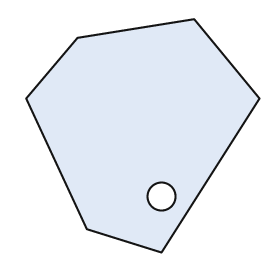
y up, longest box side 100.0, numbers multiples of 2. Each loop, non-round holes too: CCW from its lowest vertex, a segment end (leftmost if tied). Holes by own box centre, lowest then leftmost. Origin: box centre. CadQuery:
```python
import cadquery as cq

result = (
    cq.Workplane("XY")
    .moveTo(8.0, -50.0)
    .lineTo(50.0, 16.0)
    .lineTo(22.0, 50.0)
    .lineTo(-28.0, 42.0)
    .lineTo(-50.0, 16.0)
    .lineTo(-24.0, -40.0)
    .close()
    .moveTo(8.0, -26.0)
    .circle(6.0)
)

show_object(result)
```